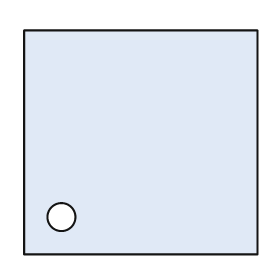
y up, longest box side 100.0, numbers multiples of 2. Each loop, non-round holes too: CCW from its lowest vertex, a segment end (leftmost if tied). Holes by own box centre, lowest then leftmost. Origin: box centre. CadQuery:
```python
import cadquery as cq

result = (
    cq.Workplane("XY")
    .moveTo(-50.0, -48.0)
    .lineTo(50.0, -48.0)
    .lineTo(50.0, 48.0)
    .lineTo(-50.0, 48.0)
    .close()
    .moveTo(-34.0, -32.0)
    .circle(6.0)
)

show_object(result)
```